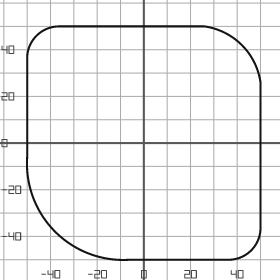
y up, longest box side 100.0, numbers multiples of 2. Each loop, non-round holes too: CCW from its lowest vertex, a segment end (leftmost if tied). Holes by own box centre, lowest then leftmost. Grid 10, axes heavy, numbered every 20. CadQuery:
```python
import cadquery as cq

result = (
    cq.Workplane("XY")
    .moveTo(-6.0, -50.0)
    .lineTo(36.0, -50.0)
    .threePointArc((46.0, -46.0), (50.0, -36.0))
    .lineTo(50.0, 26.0)
    .threePointArc((42.0, 42.0), (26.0, 50.0))
    .lineTo(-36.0, 50.0)
    .threePointArc((-46.0, 46.0), (-50.0, 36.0))
    .lineTo(-50.0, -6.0)
    .threePointArc((-38.0, -38.0), (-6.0, -50.0))
    .close()
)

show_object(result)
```